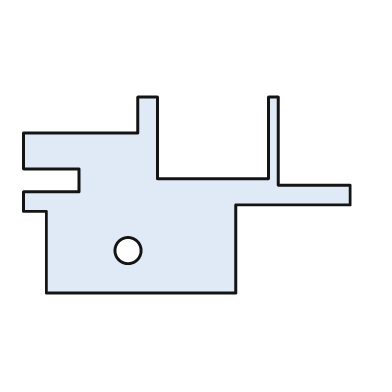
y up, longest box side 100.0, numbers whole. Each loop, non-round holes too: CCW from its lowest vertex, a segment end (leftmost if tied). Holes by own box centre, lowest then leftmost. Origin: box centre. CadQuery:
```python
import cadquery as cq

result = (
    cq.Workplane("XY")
    .moveTo(-43.0, -30.0)
    .lineTo(15.0, -30.0)
    .lineTo(15.0, -3.0)
    .lineTo(50.0, -3.0)
    .lineTo(50.0, 3.0)
    .lineTo(28.0, 3.0)
    .lineTo(28.0, 30.0)
    .lineTo(25.0, 30.0)
    .lineTo(25.0, 5.0)
    .lineTo(-9.0, 5.0)
    .lineTo(-9.0, 30.0)
    .lineTo(-15.0, 30.0)
    .lineTo(-15.0, 19.0)
    .lineTo(-50.0, 19.0)
    .lineTo(-50.0, 8.0)
    .lineTo(-33.0, 8.0)
    .lineTo(-33.0, 1.0)
    .lineTo(-50.0, 1.0)
    .lineTo(-50.0, -5.0)
    .lineTo(-43.0, -5.0)
    .close()
    .moveTo(-18.0, -17.0)
    .circle(4.0)
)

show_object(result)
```